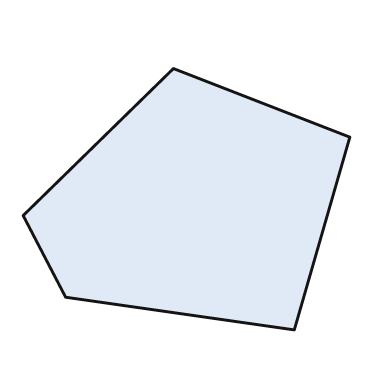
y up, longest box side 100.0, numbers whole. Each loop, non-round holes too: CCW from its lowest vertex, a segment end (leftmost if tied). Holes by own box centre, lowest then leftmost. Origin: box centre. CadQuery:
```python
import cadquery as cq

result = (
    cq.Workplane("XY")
    .moveTo(33.0, -40.0)
    .lineTo(50.0, 19.0)
    .lineTo(-4.0, 40.0)
    .lineTo(-50.0, -5.0)
    .lineTo(-37.0, -30.0)
    .close()
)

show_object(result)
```